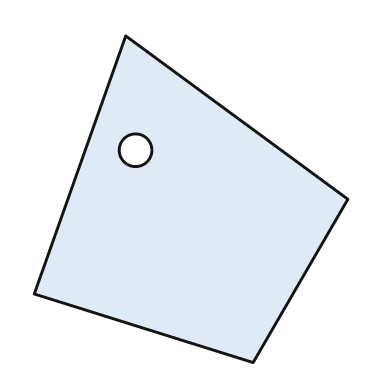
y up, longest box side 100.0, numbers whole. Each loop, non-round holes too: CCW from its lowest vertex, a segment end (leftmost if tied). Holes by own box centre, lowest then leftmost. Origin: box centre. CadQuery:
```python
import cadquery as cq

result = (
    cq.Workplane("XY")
    .moveTo(19.0, -50.0)
    .lineTo(48.0, 0.0)
    .lineTo(-20.0, 50.0)
    .lineTo(-48.0, -29.0)
    .close()
    .moveTo(-17.0, 15.0)
    .circle(5.0)
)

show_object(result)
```